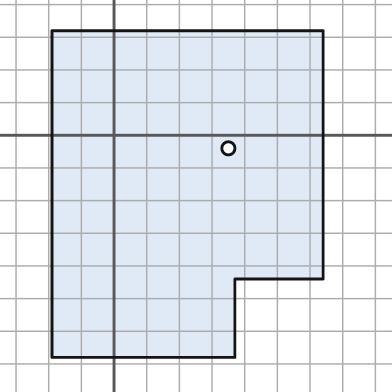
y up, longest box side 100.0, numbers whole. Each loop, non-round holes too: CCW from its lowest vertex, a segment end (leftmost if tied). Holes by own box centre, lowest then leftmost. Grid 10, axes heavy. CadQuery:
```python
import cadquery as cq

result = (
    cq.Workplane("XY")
    .moveTo(-19.0, -68.0)
    .lineTo(37.0, -68.0)
    .lineTo(37.0, -44.0)
    .lineTo(64.0, -44.0)
    .lineTo(64.0, 32.0)
    .lineTo(-19.0, 32.0)
    .close()
    .moveTo(35.0, -4.0)
    .circle(2.0)
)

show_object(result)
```